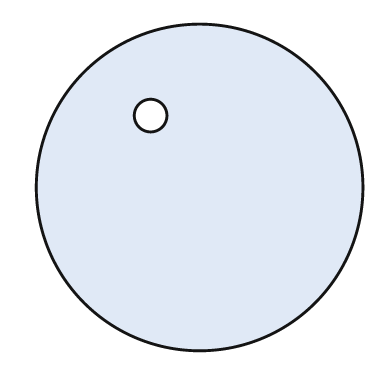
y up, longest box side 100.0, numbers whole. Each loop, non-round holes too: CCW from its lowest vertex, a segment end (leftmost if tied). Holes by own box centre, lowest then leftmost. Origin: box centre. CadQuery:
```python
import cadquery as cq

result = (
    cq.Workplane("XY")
    .moveTo(0.0, 0.0)
    .circle(50.0)
    .moveTo(-15.0, 22.0)
    .circle(5.0)
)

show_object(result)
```